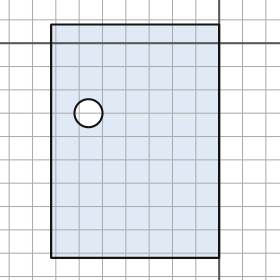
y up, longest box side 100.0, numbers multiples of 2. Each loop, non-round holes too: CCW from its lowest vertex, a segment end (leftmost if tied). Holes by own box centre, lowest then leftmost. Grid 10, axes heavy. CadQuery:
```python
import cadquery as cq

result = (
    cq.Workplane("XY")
    .moveTo(-72.0, -92.0)
    .lineTo(0.0, -92.0)
    .lineTo(0.0, 8.0)
    .lineTo(-72.0, 8.0)
    .close()
    .moveTo(-56.0, -30.0)
    .circle(6.0)
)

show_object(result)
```